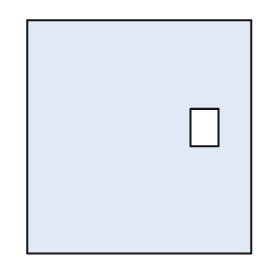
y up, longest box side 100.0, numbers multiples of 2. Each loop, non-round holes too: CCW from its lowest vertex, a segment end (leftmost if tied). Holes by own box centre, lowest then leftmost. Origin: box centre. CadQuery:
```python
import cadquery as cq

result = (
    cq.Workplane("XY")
    .moveTo(-48.0, -50.0)
    .lineTo(48.0, -50.0)
    .lineTo(48.0, 50.0)
    .lineTo(-48.0, 50.0)
    .close()
    .moveTo(22.0, -4.0)
    .lineTo(34.0, -4.0)
    .lineTo(34.0, 12.0)
    .lineTo(22.0, 12.0)
    .close()
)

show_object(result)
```